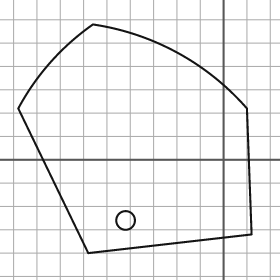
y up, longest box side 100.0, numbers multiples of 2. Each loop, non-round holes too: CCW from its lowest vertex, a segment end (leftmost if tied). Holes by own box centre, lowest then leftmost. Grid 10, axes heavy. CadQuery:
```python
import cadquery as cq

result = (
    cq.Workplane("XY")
    .moveTo(-58.0, -40.0)
    .lineTo(12.0, -32.0)
    .lineTo(10.0, 22.0)
    .threePointArc((-20.0, 46.0), (-56.0, 58.0))
    .threePointArc((-74.0, 42.0), (-88.0, 22.0))
    .close()
    .moveTo(-42.0, -26.0)
    .circle(4.0)
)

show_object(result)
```